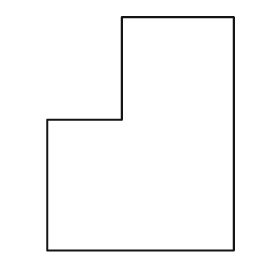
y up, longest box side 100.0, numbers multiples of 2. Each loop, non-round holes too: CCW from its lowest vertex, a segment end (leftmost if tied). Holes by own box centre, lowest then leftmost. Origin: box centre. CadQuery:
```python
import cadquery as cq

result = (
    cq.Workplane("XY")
    .moveTo(-40.0, -50.0)
    .lineTo(40.0, -50.0)
    .lineTo(40.0, 50.0)
    .lineTo(-8.0, 50.0)
    .lineTo(-8.0, 6.0)
    .lineTo(-40.0, 6.0)
    .close()
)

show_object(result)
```